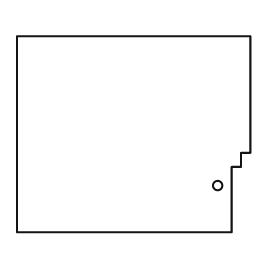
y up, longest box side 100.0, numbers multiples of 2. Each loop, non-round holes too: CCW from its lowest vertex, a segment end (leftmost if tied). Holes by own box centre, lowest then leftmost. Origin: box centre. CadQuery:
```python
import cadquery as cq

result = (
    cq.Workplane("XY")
    .moveTo(-50.0, -42.0)
    .lineTo(42.0, -42.0)
    .lineTo(42.0, -14.0)
    .lineTo(46.0, -14.0)
    .lineTo(46.0, -8.0)
    .lineTo(50.0, -8.0)
    .lineTo(50.0, 42.0)
    .lineTo(-50.0, 42.0)
    .close()
    .moveTo(36.0, -22.0)
    .circle(2.0)
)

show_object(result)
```